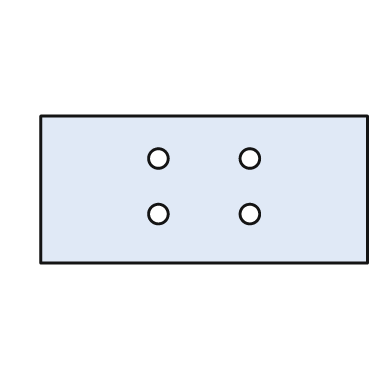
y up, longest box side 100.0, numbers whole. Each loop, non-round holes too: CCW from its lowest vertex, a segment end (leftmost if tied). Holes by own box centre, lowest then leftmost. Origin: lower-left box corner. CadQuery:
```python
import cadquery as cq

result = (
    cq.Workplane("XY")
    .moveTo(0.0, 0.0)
    .lineTo(100.0, 0.0)
    .lineTo(100.0, 45.0)
    .lineTo(0.0, 45.0)
    .close()
    .moveTo(36.0, 15.0)
    .circle(3.0)
    .moveTo(64.0, 15.0)
    .circle(3.0)
    .moveTo(36.0, 32.0)
    .circle(3.0)
    .moveTo(64.0, 32.0)
    .circle(3.0)
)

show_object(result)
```